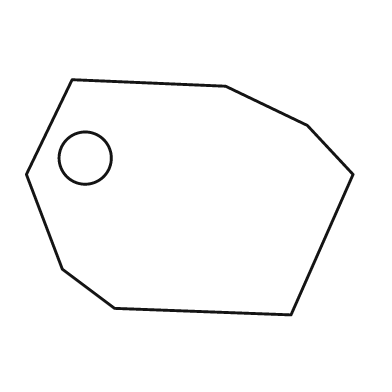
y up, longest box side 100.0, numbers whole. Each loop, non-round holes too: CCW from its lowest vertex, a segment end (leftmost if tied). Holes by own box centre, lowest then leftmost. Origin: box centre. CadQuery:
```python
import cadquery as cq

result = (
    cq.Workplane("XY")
    .moveTo(31.0, -36.0)
    .lineTo(50.0, 7.0)
    .lineTo(36.0, 22.0)
    .lineTo(11.0, 34.0)
    .lineTo(-36.0, 36.0)
    .lineTo(-50.0, 7.0)
    .lineTo(-39.0, -22.0)
    .lineTo(-23.0, -34.0)
    .close()
    .moveTo(-32.0, 12.0)
    .circle(8.0)
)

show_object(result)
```